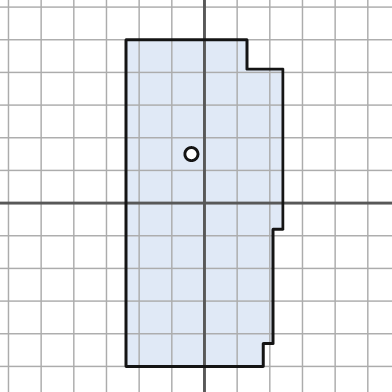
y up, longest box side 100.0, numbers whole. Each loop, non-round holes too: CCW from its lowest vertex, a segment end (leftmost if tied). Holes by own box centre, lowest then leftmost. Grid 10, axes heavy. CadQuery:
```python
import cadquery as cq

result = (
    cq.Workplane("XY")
    .moveTo(-24.0, -50.0)
    .lineTo(18.0, -50.0)
    .lineTo(18.0, -43.0)
    .lineTo(21.0, -43.0)
    .lineTo(21.0, -8.0)
    .lineTo(24.0, -8.0)
    .lineTo(24.0, 41.0)
    .lineTo(13.0, 41.0)
    .lineTo(13.0, 50.0)
    .lineTo(-24.0, 50.0)
    .close()
    .moveTo(-4.0, 15.0)
    .circle(2.0)
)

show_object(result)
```